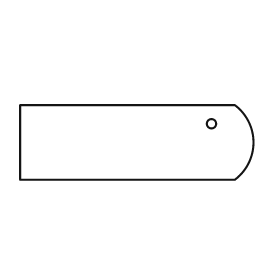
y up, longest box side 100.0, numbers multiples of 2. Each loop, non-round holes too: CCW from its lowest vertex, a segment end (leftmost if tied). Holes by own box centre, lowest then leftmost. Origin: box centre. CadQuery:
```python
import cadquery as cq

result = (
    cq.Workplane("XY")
    .moveTo(-50.0, -16.0)
    .lineTo(42.0, -16.0)
    .threePointArc((50.0, 0.0), (42.0, 16.0))
    .lineTo(-50.0, 16.0)
    .close()
    .moveTo(32.0, 8.0)
    .circle(2.0)
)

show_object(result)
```